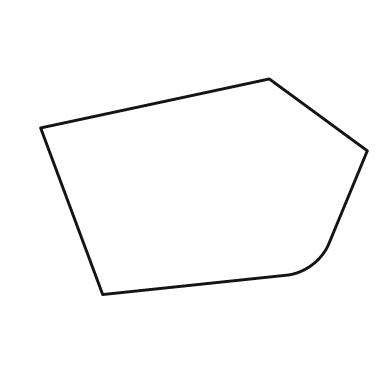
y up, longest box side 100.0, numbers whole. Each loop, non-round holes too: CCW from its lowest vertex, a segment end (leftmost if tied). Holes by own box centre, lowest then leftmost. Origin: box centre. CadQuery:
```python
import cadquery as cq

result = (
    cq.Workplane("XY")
    .moveTo(-31.0, -33.0)
    .lineTo(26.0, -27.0)
    .threePointArc((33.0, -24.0), (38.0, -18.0))
    .lineTo(50.0, 11.0)
    .lineTo(20.0, 33.0)
    .lineTo(-50.0, 18.0)
    .close()
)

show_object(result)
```